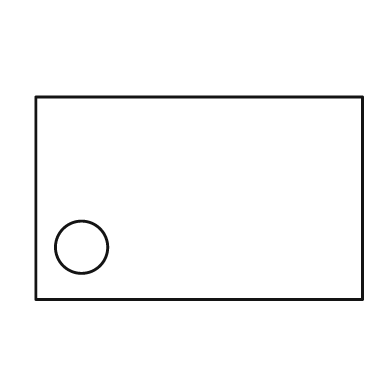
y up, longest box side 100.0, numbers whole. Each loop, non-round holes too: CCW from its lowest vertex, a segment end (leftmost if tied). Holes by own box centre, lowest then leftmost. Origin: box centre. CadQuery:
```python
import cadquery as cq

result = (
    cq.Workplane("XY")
    .moveTo(-50.0, -31.0)
    .lineTo(50.0, -31.0)
    .lineTo(50.0, 31.0)
    .lineTo(-50.0, 31.0)
    .close()
    .moveTo(-36.0, -15.0)
    .circle(8.0)
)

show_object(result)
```